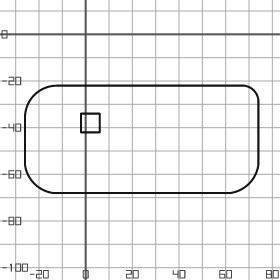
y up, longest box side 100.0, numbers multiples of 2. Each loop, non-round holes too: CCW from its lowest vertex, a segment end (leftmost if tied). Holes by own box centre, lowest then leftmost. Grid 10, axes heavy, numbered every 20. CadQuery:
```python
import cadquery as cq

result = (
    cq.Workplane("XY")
    .moveTo(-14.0, -68.0)
    .lineTo(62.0, -68.0)
    .threePointArc((70.0, -64.0), (74.0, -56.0))
    .lineTo(74.0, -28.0)
    .threePointArc((72.0, -24.0), (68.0, -22.0))
    .lineTo(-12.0, -22.0)
    .threePointArc((-22.0, -26.0), (-26.0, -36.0))
    .lineTo(-26.0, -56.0)
    .threePointArc((-22.0, -64.0), (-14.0, -68.0))
    .close()
    .moveTo(-2.0, -42.0)
    .lineTo(6.0, -42.0)
    .lineTo(6.0, -34.0)
    .lineTo(-2.0, -34.0)
    .close()
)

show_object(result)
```